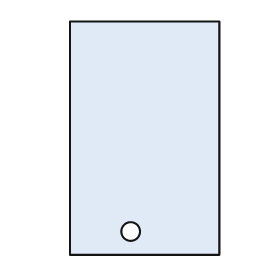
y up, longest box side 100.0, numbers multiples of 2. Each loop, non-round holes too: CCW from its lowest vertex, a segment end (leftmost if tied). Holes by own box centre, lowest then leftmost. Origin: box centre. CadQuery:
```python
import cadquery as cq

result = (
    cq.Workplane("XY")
    .moveTo(-32.0, -50.0)
    .lineTo(32.0, -50.0)
    .lineTo(32.0, 50.0)
    .lineTo(-32.0, 50.0)
    .close()
    .moveTo(-6.0, -40.0)
    .circle(4.0)
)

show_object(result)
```